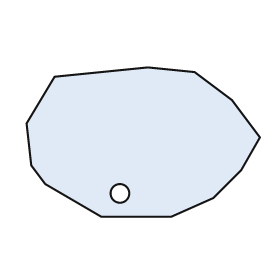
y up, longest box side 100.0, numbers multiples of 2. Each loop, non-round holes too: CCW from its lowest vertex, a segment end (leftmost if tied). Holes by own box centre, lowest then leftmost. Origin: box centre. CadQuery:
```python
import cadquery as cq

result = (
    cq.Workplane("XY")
    .moveTo(-18.0, -32.0)
    .lineTo(12.0, -32.0)
    .lineTo(30.0, -24.0)
    .lineTo(42.0, -12.0)
    .lineTo(50.0, 2.0)
    .lineTo(38.0, 18.0)
    .lineTo(22.0, 30.0)
    .lineTo(2.0, 32.0)
    .lineTo(-38.0, 28.0)
    .lineTo(-50.0, 8.0)
    .lineTo(-48.0, -10.0)
    .lineTo(-42.0, -18.0)
    .close()
    .moveTo(-10.0, -22.0)
    .circle(4.0)
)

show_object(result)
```